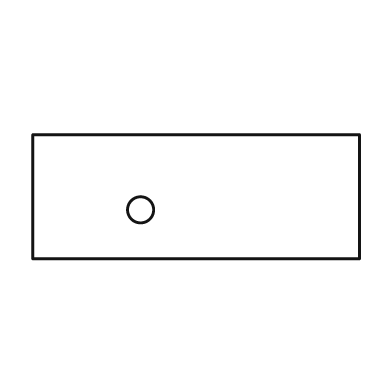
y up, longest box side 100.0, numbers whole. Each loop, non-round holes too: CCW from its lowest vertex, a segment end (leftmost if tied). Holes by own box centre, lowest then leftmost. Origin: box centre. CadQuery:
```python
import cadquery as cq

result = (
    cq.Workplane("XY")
    .moveTo(-50.0, -19.0)
    .lineTo(50.0, -19.0)
    .lineTo(50.0, 19.0)
    .lineTo(-50.0, 19.0)
    .close()
    .moveTo(-17.0, -4.0)
    .circle(4.0)
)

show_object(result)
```